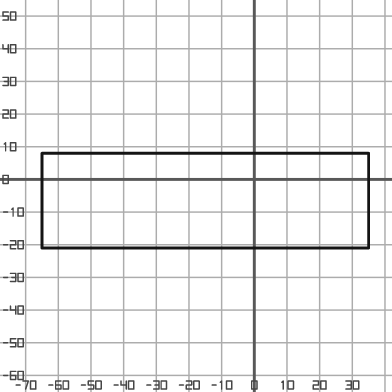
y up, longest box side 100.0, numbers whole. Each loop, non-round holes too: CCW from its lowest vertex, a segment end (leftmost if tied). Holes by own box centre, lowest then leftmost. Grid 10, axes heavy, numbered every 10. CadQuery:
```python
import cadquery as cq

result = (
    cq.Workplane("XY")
    .moveTo(-65.0, -21.0)
    .lineTo(35.0, -21.0)
    .lineTo(35.0, 8.0)
    .lineTo(-65.0, 8.0)
    .close()
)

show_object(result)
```